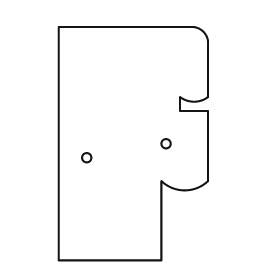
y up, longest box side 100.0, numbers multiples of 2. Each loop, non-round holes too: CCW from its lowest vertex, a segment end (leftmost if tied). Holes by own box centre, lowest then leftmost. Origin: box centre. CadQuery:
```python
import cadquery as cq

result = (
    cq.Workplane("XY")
    .moveTo(-32.0, -50.0)
    .lineTo(12.0, -50.0)
    .lineTo(12.0, -16.0)
    .threePointArc((22.0, -20.0), (32.0, -16.0))
    .lineTo(32.0, 14.0)
    .lineTo(20.0, 14.0)
    .lineTo(20.0, 20.0)
    .threePointArc((26.0, 18.0), (32.0, 20.0))
    .lineTo(32.0, 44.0)
    .threePointArc((30.0, 48.0), (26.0, 50.0))
    .lineTo(-32.0, 50.0)
    .close()
    .moveTo(-20.0, -6.0)
    .circle(2.0)
    .moveTo(14.0, 0.0)
    .circle(2.0)
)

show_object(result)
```